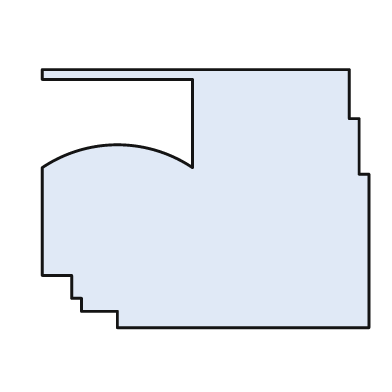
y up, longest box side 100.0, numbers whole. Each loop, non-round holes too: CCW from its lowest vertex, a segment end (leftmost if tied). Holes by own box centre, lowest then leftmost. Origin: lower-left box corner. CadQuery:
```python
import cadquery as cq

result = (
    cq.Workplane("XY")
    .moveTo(23.0, 0.0)
    .lineTo(100.0, 0.0)
    .lineTo(100.0, 47.0)
    .lineTo(97.0, 47.0)
    .lineTo(97.0, 64.0)
    .lineTo(94.0, 64.0)
    .lineTo(94.0, 79.0)
    .lineTo(0.0, 79.0)
    .lineTo(0.0, 76.0)
    .lineTo(46.0, 76.0)
    .lineTo(46.0, 49.0)
    .threePointArc((23.0, 56.0), (0.0, 49.0))
    .lineTo(0.0, 16.0)
    .lineTo(9.0, 16.0)
    .lineTo(9.0, 9.0)
    .lineTo(12.0, 9.0)
    .lineTo(12.0, 5.0)
    .lineTo(23.0, 5.0)
    .close()
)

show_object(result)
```